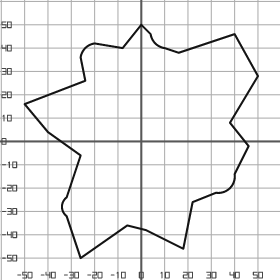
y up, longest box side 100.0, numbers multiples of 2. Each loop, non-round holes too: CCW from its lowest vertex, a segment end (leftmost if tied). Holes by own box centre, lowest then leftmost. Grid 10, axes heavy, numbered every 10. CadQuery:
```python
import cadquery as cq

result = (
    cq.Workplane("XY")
    .moveTo(-26.0, -50.0)
    .lineTo(-6.0, -36.0)
    .lineTo(2.0, -38.0)
    .lineTo(18.0, -46.0)
    .lineTo(22.0, -26.0)
    .lineTo(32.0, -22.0)
    .threePointArc((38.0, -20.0), (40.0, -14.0))
    .lineTo(46.0, -2.0)
    .lineTo(38.0, 8.0)
    .lineTo(50.0, 28.0)
    .lineTo(40.0, 46.0)
    .lineTo(16.0, 38.0)
    .lineTo(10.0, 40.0)
    .threePointArc((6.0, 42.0), (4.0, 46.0))
    .lineTo(0.0, 50.0)
    .lineTo(-8.0, 40.0)
    .lineTo(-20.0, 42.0)
    .threePointArc((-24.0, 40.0), (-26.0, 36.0))
    .lineTo(-24.0, 26.0)
    .lineTo(-50.0, 16.0)
    .lineTo(-40.0, 4.0)
    .lineTo(-26.0, -6.0)
    .lineTo(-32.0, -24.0)
    .threePointArc((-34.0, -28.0), (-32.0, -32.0))
    .close()
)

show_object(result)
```